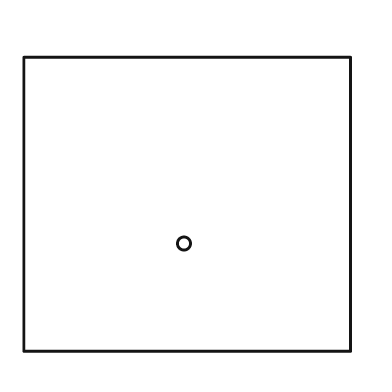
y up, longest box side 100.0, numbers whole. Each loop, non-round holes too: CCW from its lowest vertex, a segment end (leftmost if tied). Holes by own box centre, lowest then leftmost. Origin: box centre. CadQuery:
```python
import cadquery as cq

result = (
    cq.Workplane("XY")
    .moveTo(-50.0, -45.0)
    .lineTo(50.0, -45.0)
    .lineTo(50.0, 45.0)
    .lineTo(-50.0, 45.0)
    .close()
    .moveTo(-1.0, -12.0)
    .circle(2.0)
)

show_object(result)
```